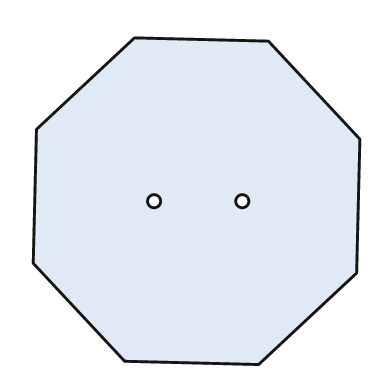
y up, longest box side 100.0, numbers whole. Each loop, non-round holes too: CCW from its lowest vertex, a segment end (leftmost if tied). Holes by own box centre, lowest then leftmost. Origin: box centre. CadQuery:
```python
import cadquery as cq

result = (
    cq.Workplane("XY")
    .moveTo(19.0, -50.0)
    .lineTo(49.0, -22.0)
    .lineTo(50.0, 19.0)
    .lineTo(22.0, 49.0)
    .lineTo(-19.0, 50.0)
    .lineTo(-49.0, 22.0)
    .lineTo(-50.0, -19.0)
    .lineTo(-22.0, -49.0)
    .close()
    .moveTo(-13.0, 0.0)
    .circle(2.0)
    .moveTo(14.0, 0.0)
    .circle(2.0)
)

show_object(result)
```